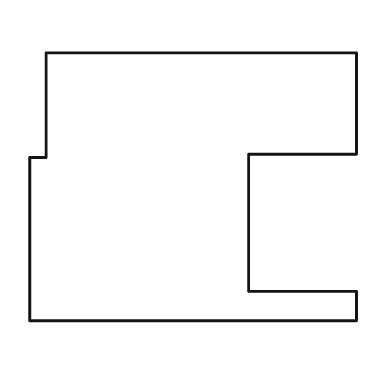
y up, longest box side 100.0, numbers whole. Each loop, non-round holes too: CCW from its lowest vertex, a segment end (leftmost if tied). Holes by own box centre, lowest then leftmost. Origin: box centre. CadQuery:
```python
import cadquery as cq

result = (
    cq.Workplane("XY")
    .moveTo(-50.0, -41.0)
    .lineTo(50.0, -41.0)
    .lineTo(50.0, -32.0)
    .lineTo(17.0, -32.0)
    .lineTo(17.0, 10.0)
    .lineTo(50.0, 10.0)
    .lineTo(50.0, 41.0)
    .lineTo(-45.0, 41.0)
    .lineTo(-45.0, 9.0)
    .lineTo(-50.0, 9.0)
    .close()
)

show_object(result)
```